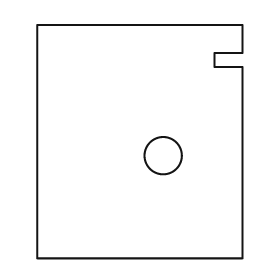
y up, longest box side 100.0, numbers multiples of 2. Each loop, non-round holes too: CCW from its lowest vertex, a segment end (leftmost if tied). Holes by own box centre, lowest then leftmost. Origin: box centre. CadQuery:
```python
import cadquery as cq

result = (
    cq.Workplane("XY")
    .moveTo(-44.0, -50.0)
    .lineTo(44.0, -50.0)
    .lineTo(44.0, 32.0)
    .lineTo(32.0, 32.0)
    .lineTo(32.0, 38.0)
    .lineTo(44.0, 38.0)
    .lineTo(44.0, 50.0)
    .lineTo(-44.0, 50.0)
    .close()
    .moveTo(10.0, -6.0)
    .circle(8.0)
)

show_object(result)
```